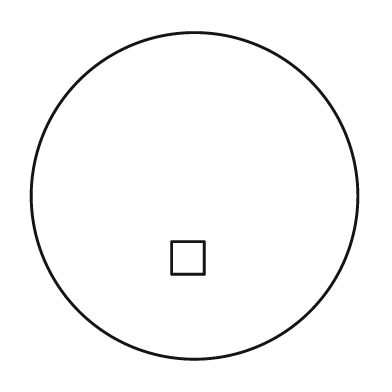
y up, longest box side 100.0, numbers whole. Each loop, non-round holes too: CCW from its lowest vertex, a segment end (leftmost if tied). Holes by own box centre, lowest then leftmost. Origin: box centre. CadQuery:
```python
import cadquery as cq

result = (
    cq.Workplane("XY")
    .moveTo(0.0, 0.0)
    .circle(50.0)
    .moveTo(-7.0, -24.0)
    .lineTo(3.0, -24.0)
    .lineTo(3.0, -14.0)
    .lineTo(-7.0, -14.0)
    .close()
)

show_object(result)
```